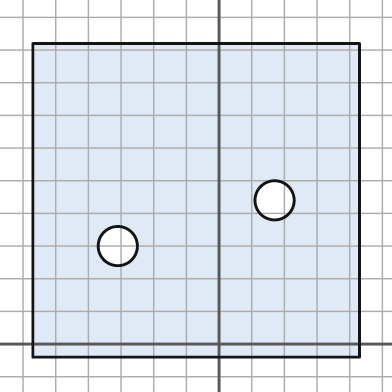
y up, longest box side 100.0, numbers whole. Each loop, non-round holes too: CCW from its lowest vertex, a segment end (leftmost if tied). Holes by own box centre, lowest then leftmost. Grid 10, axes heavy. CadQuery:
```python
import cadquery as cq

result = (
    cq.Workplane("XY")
    .moveTo(-57.0, -4.0)
    .lineTo(43.0, -4.0)
    .lineTo(43.0, 92.0)
    .lineTo(-57.0, 92.0)
    .close()
    .moveTo(-31.0, 30.0)
    .circle(6.0)
    .moveTo(17.0, 44.0)
    .circle(6.0)
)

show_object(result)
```